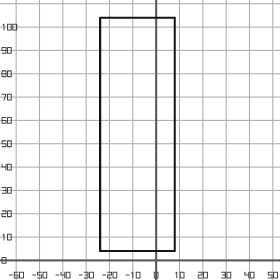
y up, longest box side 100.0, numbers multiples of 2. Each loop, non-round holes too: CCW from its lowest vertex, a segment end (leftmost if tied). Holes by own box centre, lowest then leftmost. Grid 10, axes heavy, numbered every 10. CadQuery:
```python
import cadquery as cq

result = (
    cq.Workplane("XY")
    .moveTo(-24.0, 4.0)
    .lineTo(8.0, 4.0)
    .lineTo(8.0, 104.0)
    .lineTo(-24.0, 104.0)
    .close()
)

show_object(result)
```